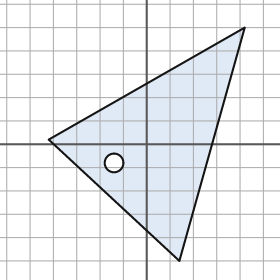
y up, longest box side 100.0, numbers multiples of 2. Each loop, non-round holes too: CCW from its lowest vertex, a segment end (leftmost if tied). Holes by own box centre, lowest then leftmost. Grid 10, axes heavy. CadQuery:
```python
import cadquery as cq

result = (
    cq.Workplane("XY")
    .moveTo(14.0, -50.0)
    .lineTo(42.0, 50.0)
    .lineTo(-42.0, 2.0)
    .close()
    .moveTo(-14.0, -8.0)
    .circle(4.0)
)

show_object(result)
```